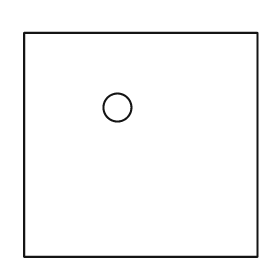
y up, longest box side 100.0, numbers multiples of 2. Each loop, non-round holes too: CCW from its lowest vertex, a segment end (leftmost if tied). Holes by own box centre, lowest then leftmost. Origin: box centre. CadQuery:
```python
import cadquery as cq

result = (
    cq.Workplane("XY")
    .moveTo(-50.0, -48.0)
    .lineTo(50.0, -48.0)
    .lineTo(50.0, 48.0)
    .lineTo(-50.0, 48.0)
    .close()
    .moveTo(-10.0, 16.0)
    .circle(6.0)
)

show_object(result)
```